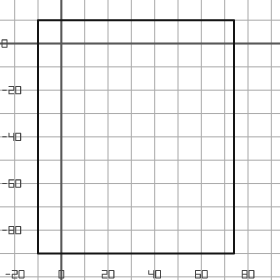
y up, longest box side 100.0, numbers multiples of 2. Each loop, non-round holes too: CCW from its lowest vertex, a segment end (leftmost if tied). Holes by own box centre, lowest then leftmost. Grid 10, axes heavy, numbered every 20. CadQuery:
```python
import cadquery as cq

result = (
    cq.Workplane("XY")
    .moveTo(-10.0, -90.0)
    .lineTo(74.0, -90.0)
    .lineTo(74.0, 10.0)
    .lineTo(-10.0, 10.0)
    .close()
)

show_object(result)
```